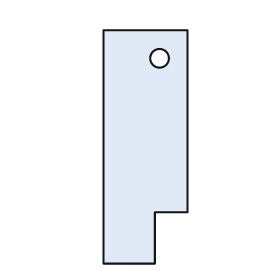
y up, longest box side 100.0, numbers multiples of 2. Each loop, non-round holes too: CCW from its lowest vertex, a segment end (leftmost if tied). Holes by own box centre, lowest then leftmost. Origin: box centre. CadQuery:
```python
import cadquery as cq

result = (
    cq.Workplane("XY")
    .moveTo(-18.0, -50.0)
    .lineTo(4.0, -50.0)
    .lineTo(4.0, -28.0)
    .lineTo(18.0, -28.0)
    .lineTo(18.0, 50.0)
    .lineTo(-18.0, 50.0)
    .close()
    .moveTo(6.0, 38.0)
    .circle(4.0)
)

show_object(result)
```